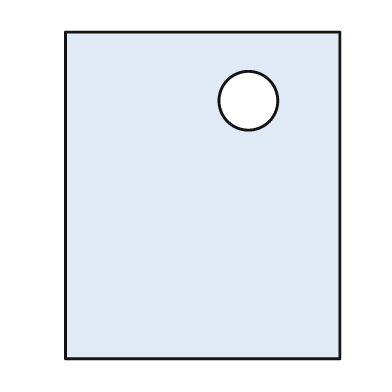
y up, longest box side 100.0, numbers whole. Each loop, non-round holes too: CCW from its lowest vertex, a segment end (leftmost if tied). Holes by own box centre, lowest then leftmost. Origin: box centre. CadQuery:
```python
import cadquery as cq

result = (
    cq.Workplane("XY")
    .moveTo(-42.0, -50.0)
    .lineTo(42.0, -50.0)
    .lineTo(42.0, 50.0)
    .lineTo(-42.0, 50.0)
    .close()
    .moveTo(14.0, 29.0)
    .circle(9.0)
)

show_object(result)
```